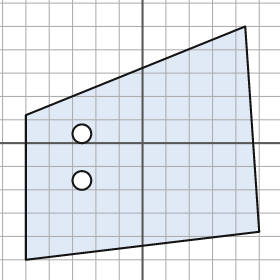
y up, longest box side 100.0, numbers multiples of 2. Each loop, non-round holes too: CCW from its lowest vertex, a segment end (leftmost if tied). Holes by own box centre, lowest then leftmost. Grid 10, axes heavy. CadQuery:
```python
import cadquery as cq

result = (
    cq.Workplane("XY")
    .moveTo(-50.0, -50.0)
    .lineTo(50.0, -38.0)
    .lineTo(44.0, 50.0)
    .lineTo(-50.0, 12.0)
    .close()
    .moveTo(-26.0, -16.0)
    .circle(4.0)
    .moveTo(-26.0, 4.0)
    .circle(4.0)
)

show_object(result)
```